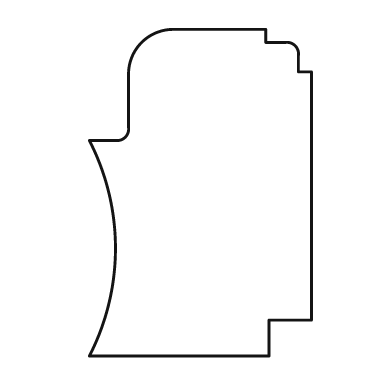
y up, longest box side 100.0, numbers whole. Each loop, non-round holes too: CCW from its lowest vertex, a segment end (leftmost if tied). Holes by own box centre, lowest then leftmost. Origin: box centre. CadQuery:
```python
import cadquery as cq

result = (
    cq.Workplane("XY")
    .moveTo(-34.0, -50.0)
    .lineTo(21.0, -50.0)
    .lineTo(21.0, -39.0)
    .lineTo(34.0, -39.0)
    .lineTo(34.0, 37.0)
    .lineTo(30.0, 37.0)
    .lineTo(30.0, 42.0)
    .threePointArc((29.0, 45.0), (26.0, 46.0))
    .lineTo(20.0, 46.0)
    .lineTo(20.0, 50.0)
    .lineTo(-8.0, 50.0)
    .threePointArc((-18.0, 46.0), (-22.0, 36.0))
    .lineTo(-22.0, 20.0)
    .threePointArc((-23.0, 17.0), (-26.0, 16.0))
    .lineTo(-34.0, 16.0)
    .threePointArc((-26.0, -17.0), (-34.0, -50.0))
    .close()
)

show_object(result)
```